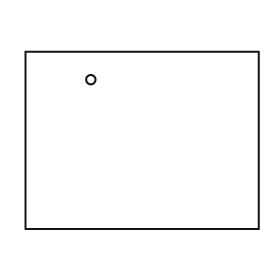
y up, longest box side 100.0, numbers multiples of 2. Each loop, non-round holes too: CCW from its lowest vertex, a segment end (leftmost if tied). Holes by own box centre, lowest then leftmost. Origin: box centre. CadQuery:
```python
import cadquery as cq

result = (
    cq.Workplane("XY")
    .moveTo(-50.0, -38.0)
    .lineTo(50.0, -38.0)
    .lineTo(50.0, 38.0)
    .lineTo(-50.0, 38.0)
    .close()
    .moveTo(-22.0, 26.0)
    .circle(2.0)
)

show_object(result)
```